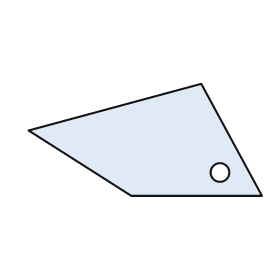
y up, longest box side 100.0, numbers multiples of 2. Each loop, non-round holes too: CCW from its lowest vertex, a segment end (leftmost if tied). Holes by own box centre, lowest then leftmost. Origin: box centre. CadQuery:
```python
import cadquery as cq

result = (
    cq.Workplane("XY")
    .moveTo(-6.0, -24.0)
    .lineTo(50.0, -24.0)
    .lineTo(24.0, 24.0)
    .lineTo(-50.0, 4.0)
    .close()
    .moveTo(32.0, -14.0)
    .circle(4.0)
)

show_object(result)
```